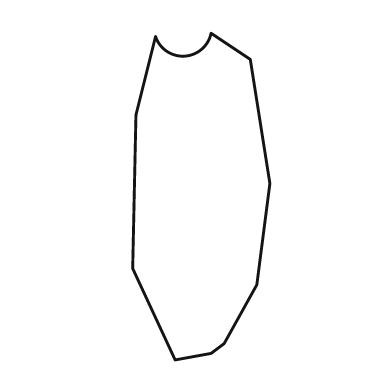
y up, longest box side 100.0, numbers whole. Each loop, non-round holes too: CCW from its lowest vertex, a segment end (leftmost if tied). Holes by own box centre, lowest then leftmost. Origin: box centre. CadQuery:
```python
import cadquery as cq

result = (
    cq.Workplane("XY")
    .moveTo(-8.0, -50.0)
    .lineTo(3.0, -48.0)
    .lineTo(7.0, -45.0)
    .lineTo(17.0, -27.0)
    .lineTo(21.0, 4.0)
    .lineTo(15.0, 42.0)
    .lineTo(3.0, 50.0)
    .threePointArc((-5.0, 43.0), (-14.0, 49.0))
    .lineTo(-20.0, 25.0)
    .lineTo(-21.0, -22.0)
    .close()
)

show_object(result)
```